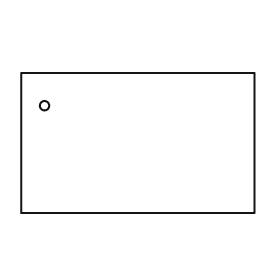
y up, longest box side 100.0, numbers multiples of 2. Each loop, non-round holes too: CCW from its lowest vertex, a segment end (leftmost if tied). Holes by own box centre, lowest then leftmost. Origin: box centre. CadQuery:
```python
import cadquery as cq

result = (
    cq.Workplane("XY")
    .moveTo(-50.0, -30.0)
    .lineTo(50.0, -30.0)
    .lineTo(50.0, 30.0)
    .lineTo(-50.0, 30.0)
    .close()
    .moveTo(-40.0, 16.0)
    .circle(2.0)
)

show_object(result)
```